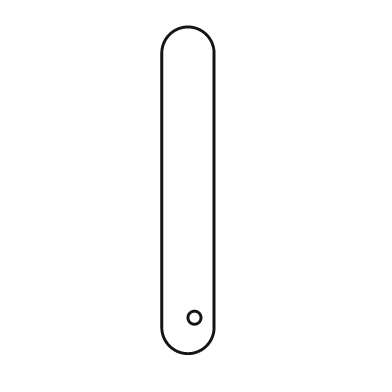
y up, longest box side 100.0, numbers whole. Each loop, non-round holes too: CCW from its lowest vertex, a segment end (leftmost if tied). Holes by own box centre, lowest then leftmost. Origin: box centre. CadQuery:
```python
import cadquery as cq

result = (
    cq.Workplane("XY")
    .moveTo(-8.0, -42.0)
    .threePointArc((0.0, -50.0), (8.0, -42.0))
    .lineTo(8.0, 42.0)
    .threePointArc((0.0, 50.0), (-8.0, 42.0))
    .close()
    .moveTo(2.0, -39.0)
    .circle(2.0)
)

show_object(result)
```